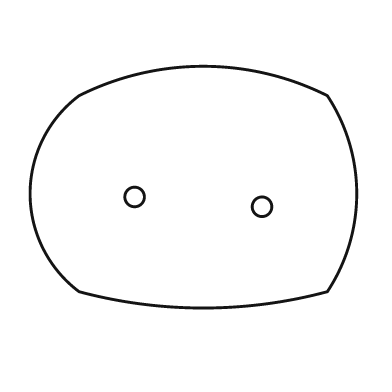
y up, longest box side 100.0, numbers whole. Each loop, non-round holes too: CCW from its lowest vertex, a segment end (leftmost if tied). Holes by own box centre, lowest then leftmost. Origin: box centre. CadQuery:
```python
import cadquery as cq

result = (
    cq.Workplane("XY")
    .moveTo(-35.0, -32.0)
    .threePointArc((3.0, -37.0), (41.0, -32.0))
    .threePointArc((50.0, -2.0), (41.0, 28.0))
    .threePointArc((3.0, 37.0), (-35.0, 28.0))
    .threePointArc((-50.0, -2.0), (-35.0, -32.0))
    .close()
    .moveTo(21.0, -6.0)
    .circle(3.0)
    .moveTo(-18.0, -3.0)
    .circle(3.0)
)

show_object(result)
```